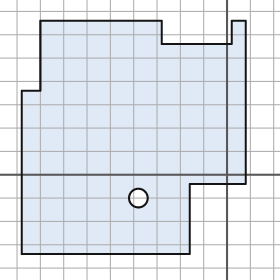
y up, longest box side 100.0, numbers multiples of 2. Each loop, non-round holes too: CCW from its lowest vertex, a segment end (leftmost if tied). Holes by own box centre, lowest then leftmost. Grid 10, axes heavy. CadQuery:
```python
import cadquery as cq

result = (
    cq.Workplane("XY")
    .moveTo(-88.0, -34.0)
    .lineTo(-16.0, -34.0)
    .lineTo(-16.0, -4.0)
    .lineTo(8.0, -4.0)
    .lineTo(8.0, 66.0)
    .lineTo(2.0, 66.0)
    .lineTo(2.0, 56.0)
    .lineTo(-28.0, 56.0)
    .lineTo(-28.0, 66.0)
    .lineTo(-80.0, 66.0)
    .lineTo(-80.0, 36.0)
    .lineTo(-88.0, 36.0)
    .close()
    .moveTo(-38.0, -10.0)
    .circle(4.0)
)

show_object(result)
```